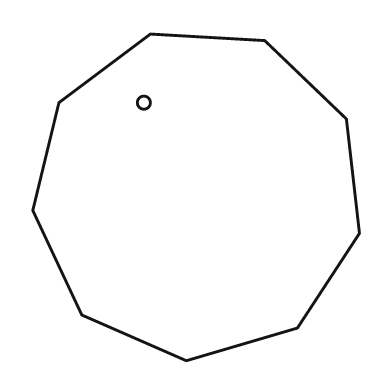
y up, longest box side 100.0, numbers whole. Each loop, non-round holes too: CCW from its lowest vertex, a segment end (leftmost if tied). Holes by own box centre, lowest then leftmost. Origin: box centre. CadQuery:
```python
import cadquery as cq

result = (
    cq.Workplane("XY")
    .moveTo(-3.0, -50.0)
    .lineTo(31.0, -40.0)
    .lineTo(50.0, -11.0)
    .lineTo(46.0, 24.0)
    .lineTo(21.0, 48.0)
    .lineTo(-14.0, 50.0)
    .lineTo(-42.0, 29.0)
    .lineTo(-50.0, -4.0)
    .lineTo(-35.0, -36.0)
    .close()
    .moveTo(-16.0, 29.0)
    .circle(2.0)
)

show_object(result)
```